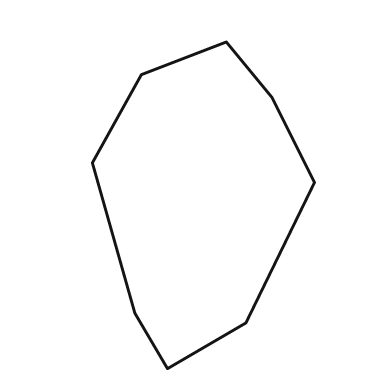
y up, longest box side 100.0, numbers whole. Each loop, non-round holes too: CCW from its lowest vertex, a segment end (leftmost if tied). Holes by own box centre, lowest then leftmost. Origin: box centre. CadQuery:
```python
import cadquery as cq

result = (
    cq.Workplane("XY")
    .moveTo(-11.0, -50.0)
    .lineTo(13.0, -36.0)
    .lineTo(34.0, 7.0)
    .lineTo(21.0, 33.0)
    .lineTo(7.0, 50.0)
    .lineTo(-19.0, 40.0)
    .lineTo(-34.0, 13.0)
    .lineTo(-21.0, -33.0)
    .close()
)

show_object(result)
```